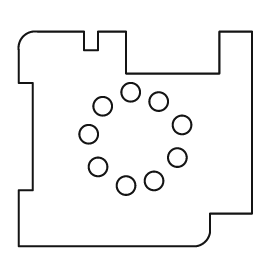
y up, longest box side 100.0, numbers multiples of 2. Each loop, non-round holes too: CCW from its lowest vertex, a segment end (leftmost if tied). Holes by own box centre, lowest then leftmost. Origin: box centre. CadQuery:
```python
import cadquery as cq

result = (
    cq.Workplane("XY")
    .moveTo(-50.0, -46.0)
    .lineTo(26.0, -46.0)
    .threePointArc((30.0, -44.0), (32.0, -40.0))
    .lineTo(32.0, -32.0)
    .lineTo(50.0, -32.0)
    .lineTo(50.0, 46.0)
    .lineTo(36.0, 46.0)
    .lineTo(36.0, 28.0)
    .lineTo(-4.0, 28.0)
    .lineTo(-4.0, 46.0)
    .lineTo(-16.0, 46.0)
    .lineTo(-16.0, 38.0)
    .lineTo(-22.0, 38.0)
    .lineTo(-22.0, 46.0)
    .lineTo(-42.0, 46.0)
    .threePointArc((-48.0, 44.0), (-50.0, 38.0))
    .lineTo(-50.0, 24.0)
    .lineTo(-44.0, 24.0)
    .lineTo(-44.0, -22.0)
    .lineTo(-50.0, -22.0)
    .close()
    .moveTo(-4.0, -20.0)
    .circle(4.0)
    .moveTo(8.0, -18.0)
    .circle(4.0)
    .moveTo(-16.0, -12.0)
    .circle(4.0)
    .moveTo(18.0, -8.0)
    .circle(4.0)
    .moveTo(-20.0, 2.0)
    .circle(4.0)
    .moveTo(20.0, 6.0)
    .circle(4.0)
    .moveTo(-14.0, 14.0)
    .circle(4.0)
    .moveTo(10.0, 16.0)
    .circle(4.0)
    .moveTo(-2.0, 20.0)
    .circle(4.0)
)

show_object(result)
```